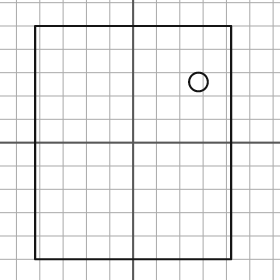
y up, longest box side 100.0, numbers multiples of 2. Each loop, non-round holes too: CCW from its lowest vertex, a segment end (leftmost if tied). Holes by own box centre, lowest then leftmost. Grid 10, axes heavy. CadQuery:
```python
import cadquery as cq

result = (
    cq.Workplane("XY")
    .moveTo(-42.0, -50.0)
    .lineTo(42.0, -50.0)
    .lineTo(42.0, 50.0)
    .lineTo(-42.0, 50.0)
    .close()
    .moveTo(28.0, 26.0)
    .circle(4.0)
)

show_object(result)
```